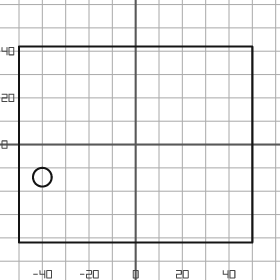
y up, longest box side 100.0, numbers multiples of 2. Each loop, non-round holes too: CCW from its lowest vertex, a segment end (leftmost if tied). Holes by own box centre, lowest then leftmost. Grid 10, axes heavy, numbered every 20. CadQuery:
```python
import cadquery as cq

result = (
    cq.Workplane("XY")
    .moveTo(-50.0, -42.0)
    .lineTo(50.0, -42.0)
    .lineTo(50.0, 42.0)
    .lineTo(-50.0, 42.0)
    .close()
    .moveTo(-40.0, -14.0)
    .circle(4.0)
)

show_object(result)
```